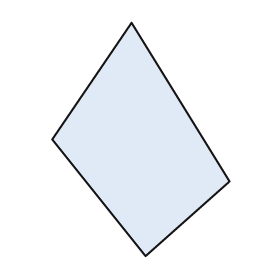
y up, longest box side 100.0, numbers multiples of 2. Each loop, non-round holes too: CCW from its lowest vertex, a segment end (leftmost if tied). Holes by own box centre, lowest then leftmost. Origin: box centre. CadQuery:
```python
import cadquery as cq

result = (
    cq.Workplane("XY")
    .moveTo(2.0, -50.0)
    .lineTo(38.0, -18.0)
    .lineTo(-4.0, 50.0)
    .lineTo(-38.0, 0.0)
    .close()
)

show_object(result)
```